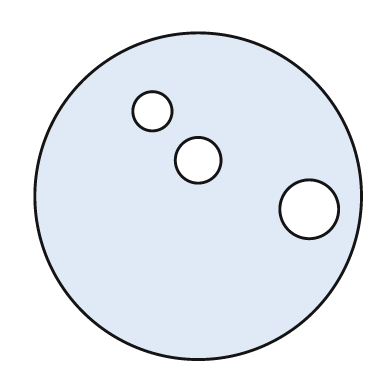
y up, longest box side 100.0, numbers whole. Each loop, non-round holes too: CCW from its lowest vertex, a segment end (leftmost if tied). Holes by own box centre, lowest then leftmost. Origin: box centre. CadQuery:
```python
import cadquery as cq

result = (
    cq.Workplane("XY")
    .moveTo(0.0, 0.0)
    .circle(50.0)
    .moveTo(34.0, -4.0)
    .circle(9.0)
    .moveTo(0.0, 11.0)
    .circle(7.0)
    .moveTo(-14.0, 26.0)
    .circle(6.0)
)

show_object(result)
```